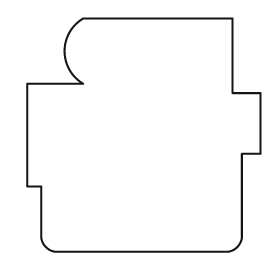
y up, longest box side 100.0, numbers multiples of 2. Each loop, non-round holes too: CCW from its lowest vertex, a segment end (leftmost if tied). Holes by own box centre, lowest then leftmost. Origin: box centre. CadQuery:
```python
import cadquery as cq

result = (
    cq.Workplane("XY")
    .moveTo(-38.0, -50.0)
    .lineTo(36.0, -50.0)
    .threePointArc((40.0, -48.0), (42.0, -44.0))
    .lineTo(42.0, -8.0)
    .lineTo(50.0, -8.0)
    .lineTo(50.0, 18.0)
    .lineTo(38.0, 18.0)
    .lineTo(38.0, 50.0)
    .lineTo(-26.0, 50.0)
    .threePointArc((-34.0, 36.0), (-26.0, 22.0))
    .lineTo(-50.0, 22.0)
    .lineTo(-50.0, -22.0)
    .lineTo(-44.0, -22.0)
    .lineTo(-44.0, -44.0)
    .threePointArc((-42.0, -48.0), (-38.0, -50.0))
    .close()
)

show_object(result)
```